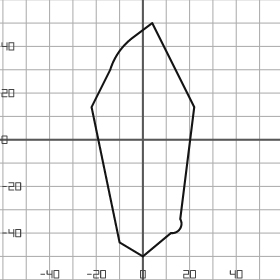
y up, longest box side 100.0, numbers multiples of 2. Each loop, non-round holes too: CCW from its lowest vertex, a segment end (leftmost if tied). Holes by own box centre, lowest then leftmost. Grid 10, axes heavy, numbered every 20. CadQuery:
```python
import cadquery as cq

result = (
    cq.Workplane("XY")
    .moveTo(0.0, -50.0)
    .lineTo(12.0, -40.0)
    .threePointArc((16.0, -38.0), (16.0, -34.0))
    .lineTo(22.0, 14.0)
    .lineTo(4.0, 50.0)
    .lineTo(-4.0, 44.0)
    .threePointArc((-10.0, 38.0), (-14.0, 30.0))
    .lineTo(-22.0, 14.0)
    .lineTo(-10.0, -44.0)
    .close()
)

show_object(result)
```